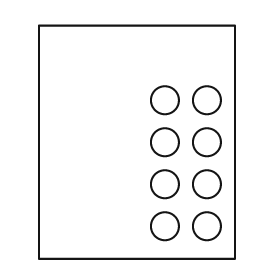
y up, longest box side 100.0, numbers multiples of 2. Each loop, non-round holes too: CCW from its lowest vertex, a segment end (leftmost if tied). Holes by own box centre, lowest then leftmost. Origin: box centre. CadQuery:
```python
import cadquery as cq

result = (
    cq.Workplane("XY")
    .moveTo(-42.0, -50.0)
    .lineTo(42.0, -50.0)
    .lineTo(42.0, 50.0)
    .lineTo(-42.0, 50.0)
    .close()
    .moveTo(12.0, -36.0)
    .circle(6.0)
    .moveTo(30.0, -36.0)
    .circle(6.0)
    .moveTo(12.0, -18.0)
    .circle(6.0)
    .moveTo(30.0, -18.0)
    .circle(6.0)
    .moveTo(12.0, 0.0)
    .circle(6.0)
    .moveTo(30.0, 0.0)
    .circle(6.0)
    .moveTo(12.0, 18.0)
    .circle(6.0)
    .moveTo(30.0, 18.0)
    .circle(6.0)
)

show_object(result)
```